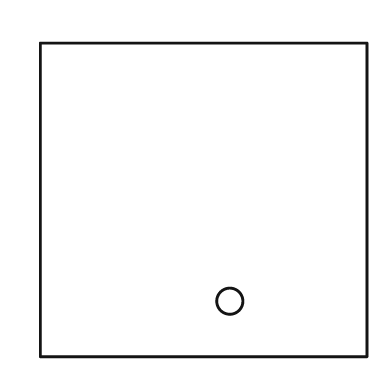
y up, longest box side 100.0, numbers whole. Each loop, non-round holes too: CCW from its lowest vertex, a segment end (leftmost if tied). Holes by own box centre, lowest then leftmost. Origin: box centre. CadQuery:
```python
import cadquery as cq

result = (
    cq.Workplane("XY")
    .moveTo(-50.0, -48.0)
    .lineTo(50.0, -48.0)
    .lineTo(50.0, 48.0)
    .lineTo(-50.0, 48.0)
    .close()
    .moveTo(8.0, -31.0)
    .circle(4.0)
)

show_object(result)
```